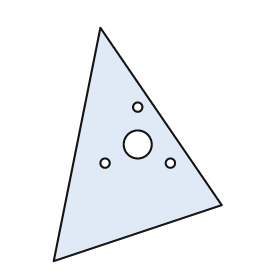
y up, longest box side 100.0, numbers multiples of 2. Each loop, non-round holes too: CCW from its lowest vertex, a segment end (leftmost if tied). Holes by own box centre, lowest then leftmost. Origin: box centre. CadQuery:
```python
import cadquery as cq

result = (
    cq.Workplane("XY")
    .moveTo(-36.0, -50.0)
    .lineTo(36.0, -26.0)
    .lineTo(-16.0, 50.0)
    .close()
    .moveTo(-14.0, -8.0)
    .circle(2.0)
    .moveTo(14.0, -8.0)
    .circle(2.0)
    .moveTo(0.0, 0.0)
    .circle(6.0)
    .moveTo(0.0, 16.0)
    .circle(2.0)
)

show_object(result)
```